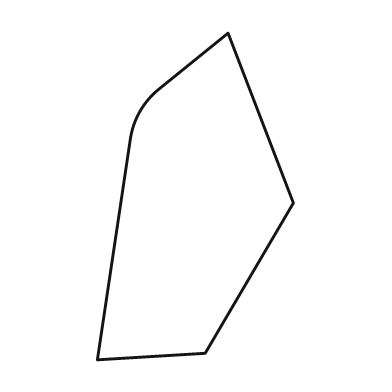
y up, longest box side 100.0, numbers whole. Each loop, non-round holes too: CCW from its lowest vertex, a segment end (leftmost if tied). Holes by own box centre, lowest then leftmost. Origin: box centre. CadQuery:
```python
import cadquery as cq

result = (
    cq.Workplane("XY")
    .moveTo(-30.0, -50.0)
    .lineTo(3.0, -48.0)
    .lineTo(30.0, -2.0)
    .lineTo(10.0, 50.0)
    .lineTo(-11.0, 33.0)
    .threePointArc((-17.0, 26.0), (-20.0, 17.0))
    .close()
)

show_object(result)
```